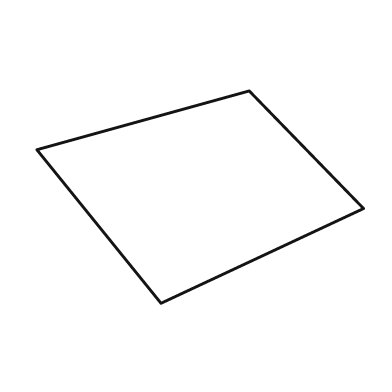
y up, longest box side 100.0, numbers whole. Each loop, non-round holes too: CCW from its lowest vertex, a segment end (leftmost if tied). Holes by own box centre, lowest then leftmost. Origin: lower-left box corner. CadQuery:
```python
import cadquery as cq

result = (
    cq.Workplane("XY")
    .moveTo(38.0, 0.0)
    .lineTo(100.0, 29.0)
    .lineTo(65.0, 65.0)
    .lineTo(0.0, 47.0)
    .close()
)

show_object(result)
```